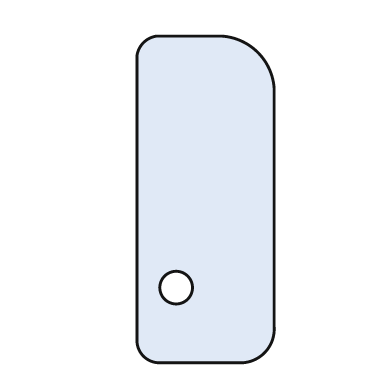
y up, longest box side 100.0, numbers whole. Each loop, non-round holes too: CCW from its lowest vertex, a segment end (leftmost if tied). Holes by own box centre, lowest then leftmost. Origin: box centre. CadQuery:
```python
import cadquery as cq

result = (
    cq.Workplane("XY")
    .moveTo(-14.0, -50.0)
    .lineTo(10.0, -50.0)
    .threePointArc((18.0, -47.0), (21.0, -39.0))
    .lineTo(21.0, 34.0)
    .threePointArc((16.0, 45.0), (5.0, 50.0))
    .lineTo(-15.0, 50.0)
    .threePointArc((-19.0, 48.0), (-21.0, 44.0))
    .lineTo(-21.0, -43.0)
    .threePointArc((-19.0, -48.0), (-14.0, -50.0))
    .close()
    .moveTo(-9.0, -27.0)
    .circle(5.0)
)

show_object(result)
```